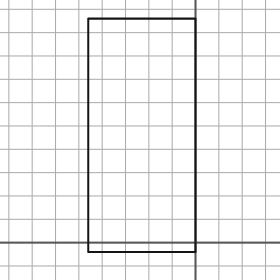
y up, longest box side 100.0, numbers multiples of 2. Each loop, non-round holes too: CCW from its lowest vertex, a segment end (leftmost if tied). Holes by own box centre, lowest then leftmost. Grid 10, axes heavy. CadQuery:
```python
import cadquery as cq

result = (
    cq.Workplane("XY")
    .moveTo(-46.0, -4.0)
    .lineTo(0.0, -4.0)
    .lineTo(0.0, 96.0)
    .lineTo(-46.0, 96.0)
    .close()
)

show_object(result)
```